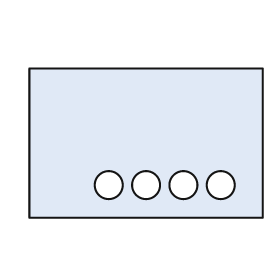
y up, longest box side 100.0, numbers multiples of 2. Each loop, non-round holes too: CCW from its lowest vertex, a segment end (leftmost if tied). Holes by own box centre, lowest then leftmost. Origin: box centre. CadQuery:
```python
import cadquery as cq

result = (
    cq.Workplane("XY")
    .moveTo(-50.0, -32.0)
    .lineTo(50.0, -32.0)
    .lineTo(50.0, 32.0)
    .lineTo(-50.0, 32.0)
    .close()
    .moveTo(-16.0, -18.0)
    .circle(6.0)
    .moveTo(0.0, -18.0)
    .circle(6.0)
    .moveTo(16.0, -18.0)
    .circle(6.0)
    .moveTo(32.0, -18.0)
    .circle(6.0)
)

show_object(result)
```